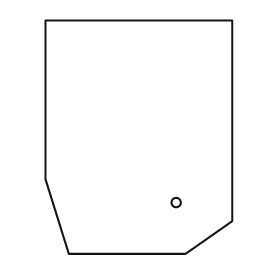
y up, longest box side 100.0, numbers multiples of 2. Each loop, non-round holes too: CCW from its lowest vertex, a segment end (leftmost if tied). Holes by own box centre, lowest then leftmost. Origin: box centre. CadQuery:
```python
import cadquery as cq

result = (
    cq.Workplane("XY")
    .moveTo(-30.0, -50.0)
    .lineTo(20.0, -50.0)
    .lineTo(40.0, -36.0)
    .lineTo(40.0, 50.0)
    .lineTo(-40.0, 50.0)
    .lineTo(-40.0, -18.0)
    .close()
    .moveTo(16.0, -28.0)
    .circle(2.0)
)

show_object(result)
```